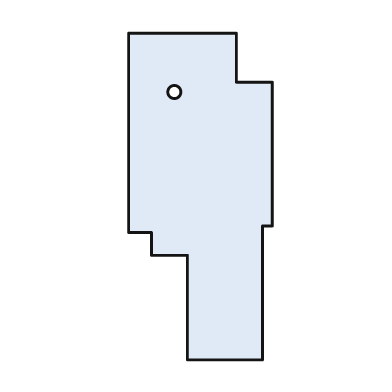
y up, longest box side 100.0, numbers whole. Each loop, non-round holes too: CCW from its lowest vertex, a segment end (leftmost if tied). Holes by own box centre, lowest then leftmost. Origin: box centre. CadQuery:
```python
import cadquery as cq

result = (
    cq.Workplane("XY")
    .moveTo(-4.0, -50.0)
    .lineTo(19.0, -50.0)
    .lineTo(19.0, -9.0)
    .lineTo(22.0, -9.0)
    .lineTo(22.0, 35.0)
    .lineTo(11.0, 35.0)
    .lineTo(11.0, 50.0)
    .lineTo(-22.0, 50.0)
    .lineTo(-22.0, -11.0)
    .lineTo(-15.0, -11.0)
    .lineTo(-15.0, -18.0)
    .lineTo(-4.0, -18.0)
    .close()
    .moveTo(-8.0, 32.0)
    .circle(2.0)
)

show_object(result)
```